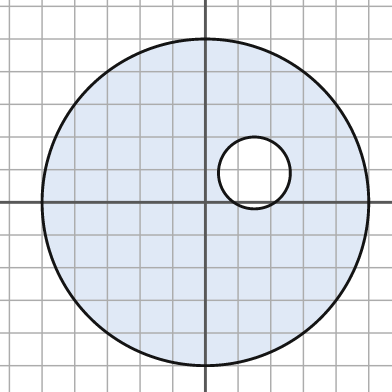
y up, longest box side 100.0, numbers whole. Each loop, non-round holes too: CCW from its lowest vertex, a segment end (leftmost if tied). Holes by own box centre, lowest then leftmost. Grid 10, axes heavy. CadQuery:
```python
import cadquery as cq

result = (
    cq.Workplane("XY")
    .moveTo(0.0, 0.0)
    .circle(50.0)
    .moveTo(15.0, 9.0)
    .circle(11.0)
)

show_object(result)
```